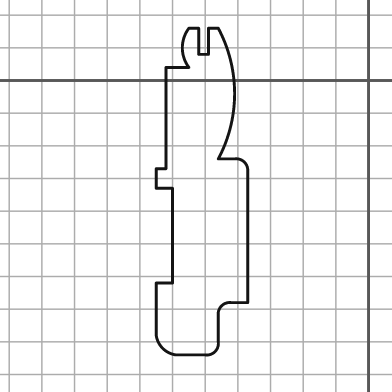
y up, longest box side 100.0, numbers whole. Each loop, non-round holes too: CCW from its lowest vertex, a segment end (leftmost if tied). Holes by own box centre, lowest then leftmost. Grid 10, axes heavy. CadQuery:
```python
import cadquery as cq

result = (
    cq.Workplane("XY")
    .moveTo(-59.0, -84.0)
    .lineTo(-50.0, -84.0)
    .threePointArc((-47.0, -83.0), (-46.0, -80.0))
    .lineTo(-46.0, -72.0)
    .threePointArc((-45.0, -69.0), (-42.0, -68.0))
    .lineTo(-37.0, -68.0)
    .lineTo(-37.0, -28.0)
    .threePointArc((-38.0, -25.0), (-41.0, -24.0))
    .lineTo(-46.0, -24.0)
    .threePointArc((-41.0, -4.0), (-46.0, 16.0))
    .lineTo(-49.0, 16.0)
    .lineTo(-49.0, 8.0)
    .lineTo(-52.0, 8.0)
    .lineTo(-52.0, 16.0)
    .lineTo(-55.0, 16.0)
    .threePointArc((-57.0, 10.0), (-55.0, 4.0))
    .lineTo(-62.0, 4.0)
    .lineTo(-62.0, -27.0)
    .lineTo(-65.0, -27.0)
    .lineTo(-65.0, -33.0)
    .lineTo(-60.0, -33.0)
    .lineTo(-60.0, -62.0)
    .lineTo(-65.0, -62.0)
    .lineTo(-65.0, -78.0)
    .threePointArc((-63.0, -82.0), (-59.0, -84.0))
    .close()
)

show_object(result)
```